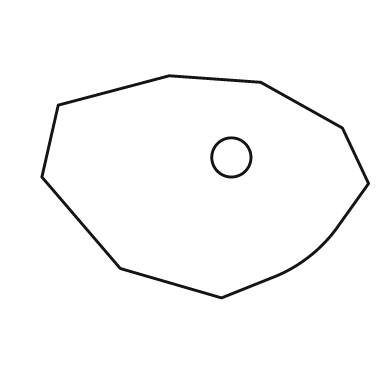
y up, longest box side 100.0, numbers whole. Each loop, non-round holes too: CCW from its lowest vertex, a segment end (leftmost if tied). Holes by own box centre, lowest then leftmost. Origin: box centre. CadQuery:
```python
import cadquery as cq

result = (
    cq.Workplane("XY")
    .moveTo(5.0, -34.0)
    .lineTo(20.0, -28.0)
    .threePointArc((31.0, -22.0), (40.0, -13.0))
    .lineTo(50.0, 1.0)
    .lineTo(42.0, 18.0)
    .lineTo(17.0, 32.0)
    .lineTo(-11.0, 34.0)
    .lineTo(-45.0, 25.0)
    .lineTo(-50.0, 3.0)
    .lineTo(-26.0, -25.0)
    .close()
    .moveTo(8.0, 9.0)
    .circle(6.0)
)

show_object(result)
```